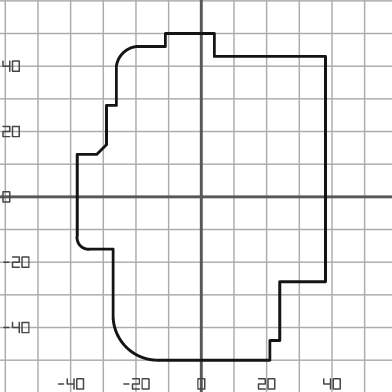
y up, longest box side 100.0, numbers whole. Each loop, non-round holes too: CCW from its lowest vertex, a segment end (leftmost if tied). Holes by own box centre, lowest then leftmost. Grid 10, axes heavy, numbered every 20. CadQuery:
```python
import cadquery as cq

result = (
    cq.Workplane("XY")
    .moveTo(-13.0, -50.0)
    .lineTo(21.0, -50.0)
    .lineTo(21.0, -44.0)
    .lineTo(24.0, -44.0)
    .lineTo(24.0, -26.0)
    .lineTo(38.0, -26.0)
    .lineTo(38.0, 43.0)
    .lineTo(4.0, 43.0)
    .lineTo(4.0, 50.0)
    .lineTo(-11.0, 50.0)
    .lineTo(-11.0, 46.0)
    .lineTo(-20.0, 46.0)
    .threePointArc((-24.0, 44.0), (-26.0, 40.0))
    .lineTo(-26.0, 28.0)
    .lineTo(-29.0, 28.0)
    .lineTo(-29.0, 16.0)
    .lineTo(-32.0, 13.0)
    .lineTo(-38.0, 13.0)
    .lineTo(-38.0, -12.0)
    .threePointArc((-37.0, -15.0), (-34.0, -16.0))
    .lineTo(-27.0, -16.0)
    .lineTo(-27.0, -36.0)
    .threePointArc((-23.0, -46.0), (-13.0, -50.0))
    .close()
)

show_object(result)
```